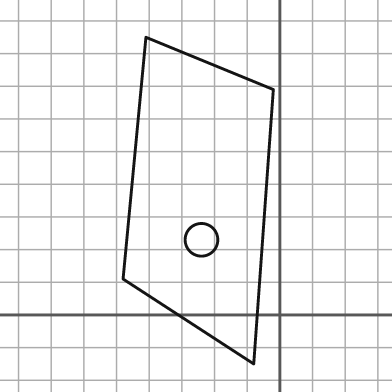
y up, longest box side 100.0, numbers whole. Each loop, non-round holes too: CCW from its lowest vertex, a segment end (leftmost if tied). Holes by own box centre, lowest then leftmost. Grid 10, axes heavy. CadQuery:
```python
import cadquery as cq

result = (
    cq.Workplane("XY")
    .moveTo(-8.0, -15.0)
    .lineTo(-2.0, 69.0)
    .lineTo(-41.0, 85.0)
    .lineTo(-48.0, 11.0)
    .close()
    .moveTo(-24.0, 23.0)
    .circle(5.0)
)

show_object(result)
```